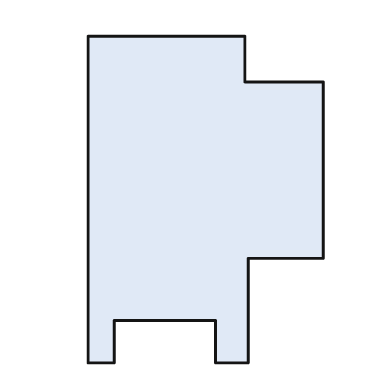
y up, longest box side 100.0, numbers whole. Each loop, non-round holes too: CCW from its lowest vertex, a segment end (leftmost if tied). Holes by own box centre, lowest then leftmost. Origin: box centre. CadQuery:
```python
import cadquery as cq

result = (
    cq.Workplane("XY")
    .moveTo(-36.0, -50.0)
    .lineTo(-28.0, -50.0)
    .lineTo(-28.0, -37.0)
    .lineTo(3.0, -37.0)
    .lineTo(3.0, -50.0)
    .lineTo(13.0, -50.0)
    .lineTo(13.0, -18.0)
    .lineTo(36.0, -18.0)
    .lineTo(36.0, 36.0)
    .lineTo(12.0, 36.0)
    .lineTo(12.0, 50.0)
    .lineTo(-36.0, 50.0)
    .close()
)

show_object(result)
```